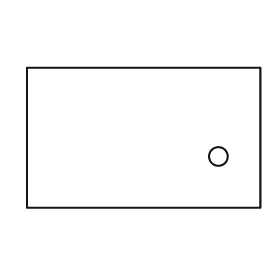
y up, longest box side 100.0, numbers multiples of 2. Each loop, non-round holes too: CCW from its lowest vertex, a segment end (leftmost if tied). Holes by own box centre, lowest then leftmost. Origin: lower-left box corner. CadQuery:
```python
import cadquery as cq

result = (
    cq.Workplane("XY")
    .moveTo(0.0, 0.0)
    .lineTo(100.0, 0.0)
    .lineTo(100.0, 60.0)
    .lineTo(0.0, 60.0)
    .close()
    .moveTo(82.0, 22.0)
    .circle(4.0)
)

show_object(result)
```